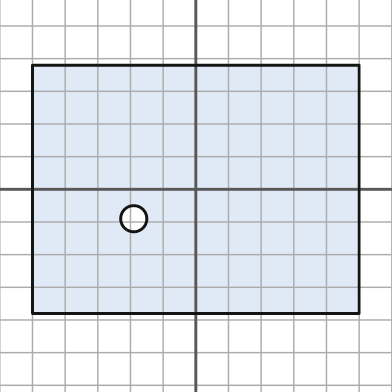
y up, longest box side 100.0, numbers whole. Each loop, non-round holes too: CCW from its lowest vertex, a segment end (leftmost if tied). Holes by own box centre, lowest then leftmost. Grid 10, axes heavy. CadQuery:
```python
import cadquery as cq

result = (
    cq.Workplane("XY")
    .moveTo(-50.0, -38.0)
    .lineTo(50.0, -38.0)
    .lineTo(50.0, 38.0)
    .lineTo(-50.0, 38.0)
    .close()
    .moveTo(-19.0, -9.0)
    .circle(4.0)
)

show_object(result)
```